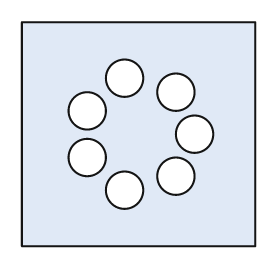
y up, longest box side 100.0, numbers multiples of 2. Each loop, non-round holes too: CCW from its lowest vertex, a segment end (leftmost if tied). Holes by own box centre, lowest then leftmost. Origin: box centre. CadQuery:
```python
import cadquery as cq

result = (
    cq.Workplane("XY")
    .moveTo(-50.0, -48.0)
    .lineTo(50.0, -48.0)
    .lineTo(50.0, 48.0)
    .lineTo(-50.0, 48.0)
    .close()
    .moveTo(-6.0, -24.0)
    .circle(8.0)
    .moveTo(16.0, -18.0)
    .circle(8.0)
    .moveTo(-22.0, -10.0)
    .circle(8.0)
    .moveTo(24.0, 0.0)
    .circle(8.0)
    .moveTo(-22.0, 10.0)
    .circle(8.0)
    .moveTo(16.0, 18.0)
    .circle(8.0)
    .moveTo(-6.0, 24.0)
    .circle(8.0)
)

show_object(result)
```